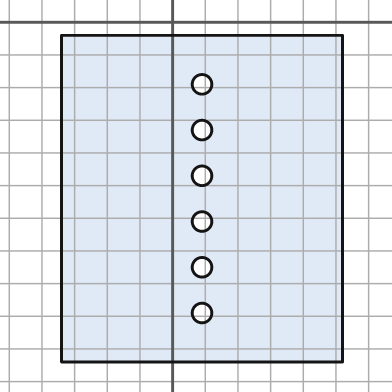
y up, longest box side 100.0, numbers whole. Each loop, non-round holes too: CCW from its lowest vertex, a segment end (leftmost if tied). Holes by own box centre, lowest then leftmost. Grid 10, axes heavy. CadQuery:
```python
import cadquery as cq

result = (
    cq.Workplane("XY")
    .moveTo(-34.0, -104.0)
    .lineTo(52.0, -104.0)
    .lineTo(52.0, -4.0)
    .lineTo(-34.0, -4.0)
    .close()
    .moveTo(9.0, -89.0)
    .circle(3.0)
    .moveTo(9.0, -75.0)
    .circle(3.0)
    .moveTo(9.0, -61.0)
    .circle(3.0)
    .moveTo(9.0, -47.0)
    .circle(3.0)
    .moveTo(9.0, -33.0)
    .circle(3.0)
    .moveTo(9.0, -19.0)
    .circle(3.0)
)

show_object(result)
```